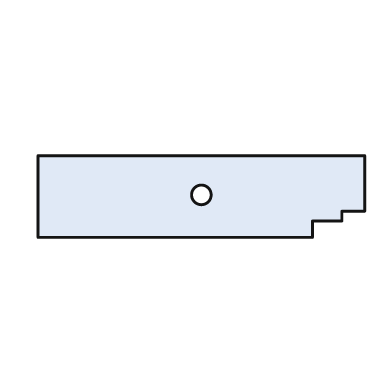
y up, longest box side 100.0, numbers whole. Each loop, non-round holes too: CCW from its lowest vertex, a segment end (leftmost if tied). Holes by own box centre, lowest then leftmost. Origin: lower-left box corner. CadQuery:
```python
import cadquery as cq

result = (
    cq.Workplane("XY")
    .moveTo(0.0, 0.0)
    .lineTo(84.0, 0.0)
    .lineTo(84.0, 5.0)
    .lineTo(93.0, 5.0)
    .lineTo(93.0, 8.0)
    .lineTo(100.0, 8.0)
    .lineTo(100.0, 25.0)
    .lineTo(0.0, 25.0)
    .close()
    .moveTo(50.0, 13.0)
    .circle(3.0)
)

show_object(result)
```